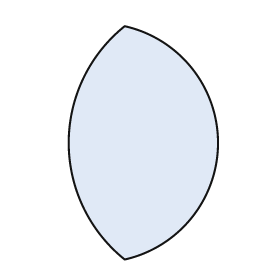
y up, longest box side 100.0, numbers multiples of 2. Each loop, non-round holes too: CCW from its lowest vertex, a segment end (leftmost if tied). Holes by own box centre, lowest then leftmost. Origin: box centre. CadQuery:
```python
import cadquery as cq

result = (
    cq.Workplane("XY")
    .moveTo(-8.0, -50.0)
    .threePointArc((32.0, 0.0), (-8.0, 50.0))
    .threePointArc((-32.0, 0.0), (-8.0, -50.0))
    .close()
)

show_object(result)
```